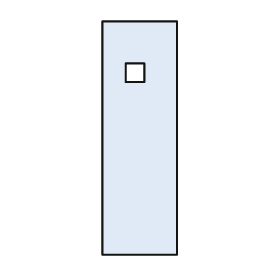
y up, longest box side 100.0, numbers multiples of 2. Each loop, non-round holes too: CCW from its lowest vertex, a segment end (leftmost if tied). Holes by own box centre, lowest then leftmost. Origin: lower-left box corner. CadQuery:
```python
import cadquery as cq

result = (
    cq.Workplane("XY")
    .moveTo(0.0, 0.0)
    .lineTo(32.0, 0.0)
    .lineTo(32.0, 100.0)
    .lineTo(0.0, 100.0)
    .close()
    .moveTo(10.0, 74.0)
    .lineTo(18.0, 74.0)
    .lineTo(18.0, 82.0)
    .lineTo(10.0, 82.0)
    .close()
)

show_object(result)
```